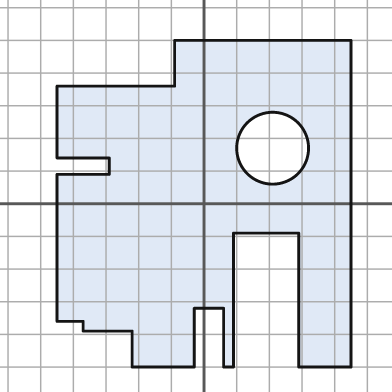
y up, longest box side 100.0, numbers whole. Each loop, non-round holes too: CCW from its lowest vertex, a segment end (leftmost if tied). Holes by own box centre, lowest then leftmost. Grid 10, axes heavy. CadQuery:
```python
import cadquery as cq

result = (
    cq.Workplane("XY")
    .moveTo(-22.0, -50.0)
    .lineTo(-3.0, -50.0)
    .lineTo(-3.0, -32.0)
    .lineTo(6.0, -32.0)
    .lineTo(6.0, -50.0)
    .lineTo(9.0, -50.0)
    .lineTo(9.0, -9.0)
    .lineTo(29.0, -9.0)
    .lineTo(29.0, -50.0)
    .lineTo(45.0, -50.0)
    .lineTo(45.0, 50.0)
    .lineTo(-9.0, 50.0)
    .lineTo(-9.0, 36.0)
    .lineTo(-45.0, 36.0)
    .lineTo(-45.0, 14.0)
    .lineTo(-29.0, 14.0)
    .lineTo(-29.0, 9.0)
    .lineTo(-45.0, 9.0)
    .lineTo(-45.0, -36.0)
    .lineTo(-37.0, -36.0)
    .lineTo(-37.0, -39.0)
    .lineTo(-22.0, -39.0)
    .close()
    .moveTo(21.0, 17.0)
    .circle(11.0)
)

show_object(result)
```